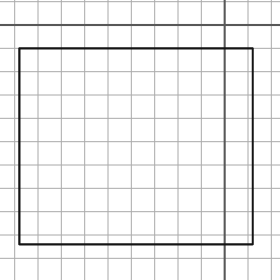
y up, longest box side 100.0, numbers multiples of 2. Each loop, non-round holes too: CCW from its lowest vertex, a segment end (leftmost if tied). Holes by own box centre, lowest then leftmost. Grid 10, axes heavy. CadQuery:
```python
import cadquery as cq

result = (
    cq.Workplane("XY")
    .moveTo(-88.0, -94.0)
    .lineTo(12.0, -94.0)
    .lineTo(12.0, -10.0)
    .lineTo(-88.0, -10.0)
    .close()
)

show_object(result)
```